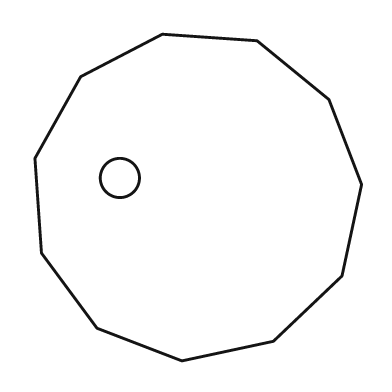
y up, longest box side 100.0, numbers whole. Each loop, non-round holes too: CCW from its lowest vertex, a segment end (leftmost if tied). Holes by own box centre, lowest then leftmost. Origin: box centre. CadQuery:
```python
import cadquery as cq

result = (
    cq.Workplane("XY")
    .moveTo(-5.0, -50.0)
    .lineTo(23.0, -44.0)
    .lineTo(44.0, -24.0)
    .lineTo(50.0, 4.0)
    .lineTo(40.0, 30.0)
    .lineTo(18.0, 48.0)
    .lineTo(-11.0, 50.0)
    .lineTo(-36.0, 37.0)
    .lineTo(-50.0, 12.0)
    .lineTo(-48.0, -17.0)
    .lineTo(-31.0, -40.0)
    .close()
    .moveTo(-24.0, 6.0)
    .circle(6.0)
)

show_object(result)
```